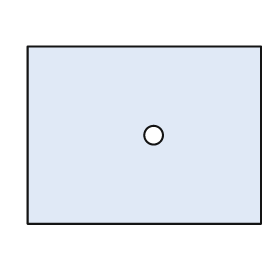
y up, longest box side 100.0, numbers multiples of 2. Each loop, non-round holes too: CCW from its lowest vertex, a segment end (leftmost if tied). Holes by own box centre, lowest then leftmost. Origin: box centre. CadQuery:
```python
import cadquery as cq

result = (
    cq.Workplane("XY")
    .moveTo(-50.0, -38.0)
    .lineTo(50.0, -38.0)
    .lineTo(50.0, 38.0)
    .lineTo(-50.0, 38.0)
    .close()
    .moveTo(4.0, 0.0)
    .circle(4.0)
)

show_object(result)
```